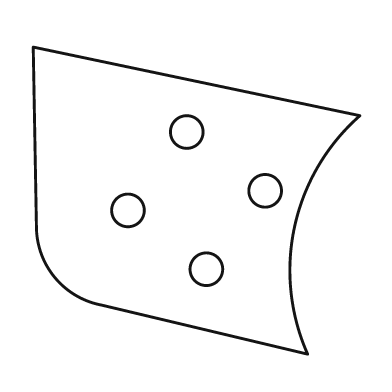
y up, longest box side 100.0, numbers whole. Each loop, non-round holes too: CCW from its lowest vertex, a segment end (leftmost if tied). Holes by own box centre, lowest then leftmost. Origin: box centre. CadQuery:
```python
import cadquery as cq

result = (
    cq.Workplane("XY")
    .moveTo(34.0, -47.0)
    .threePointArc((30.0, -8.0), (50.0, 26.0))
    .lineTo(-50.0, 47.0)
    .lineTo(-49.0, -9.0)
    .threePointArc((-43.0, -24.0), (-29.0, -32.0))
    .close()
    .moveTo(3.0, -21.0)
    .circle(5.0)
    .moveTo(-21.0, -3.0)
    .circle(5.0)
    .moveTo(21.0, 3.0)
    .circle(5.0)
    .moveTo(-3.0, 21.0)
    .circle(5.0)
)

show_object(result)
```